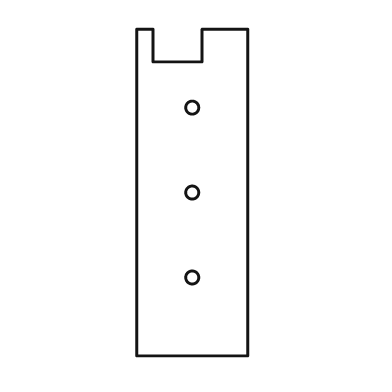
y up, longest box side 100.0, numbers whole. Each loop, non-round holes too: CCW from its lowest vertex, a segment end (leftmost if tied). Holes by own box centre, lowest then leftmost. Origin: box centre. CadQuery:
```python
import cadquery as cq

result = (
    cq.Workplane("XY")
    .moveTo(-17.0, -50.0)
    .lineTo(17.0, -50.0)
    .lineTo(17.0, 50.0)
    .lineTo(3.0, 50.0)
    .lineTo(3.0, 40.0)
    .lineTo(-12.0, 40.0)
    .lineTo(-12.0, 50.0)
    .lineTo(-17.0, 50.0)
    .close()
    .moveTo(0.0, -26.0)
    .circle(2.0)
    .moveTo(0.0, 0.0)
    .circle(2.0)
    .moveTo(0.0, 26.0)
    .circle(2.0)
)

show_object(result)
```